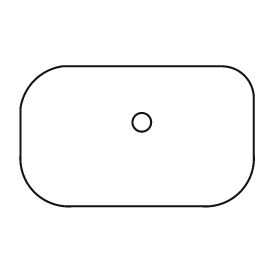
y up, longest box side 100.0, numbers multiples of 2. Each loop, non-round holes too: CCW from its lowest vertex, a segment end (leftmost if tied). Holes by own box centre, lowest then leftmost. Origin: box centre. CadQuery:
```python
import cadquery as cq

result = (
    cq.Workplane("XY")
    .moveTo(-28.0, -30.0)
    .lineTo(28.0, -30.0)
    .threePointArc((44.0, -24.0), (50.0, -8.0))
    .lineTo(50.0, 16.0)
    .threePointArc((46.0, 26.0), (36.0, 30.0))
    .lineTo(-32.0, 30.0)
    .threePointArc((-44.0, 24.0), (-50.0, 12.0))
    .lineTo(-50.0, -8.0)
    .threePointArc((-44.0, -24.0), (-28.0, -30.0))
    .close()
    .moveTo(2.0, 6.0)
    .circle(4.0)
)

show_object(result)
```